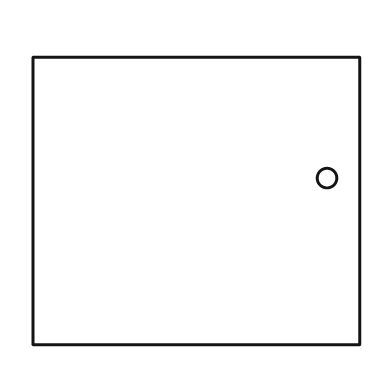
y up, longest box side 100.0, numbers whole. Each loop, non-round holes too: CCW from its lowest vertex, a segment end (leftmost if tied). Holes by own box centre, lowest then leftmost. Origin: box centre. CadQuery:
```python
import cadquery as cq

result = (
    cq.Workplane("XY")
    .moveTo(-50.0, -44.0)
    .lineTo(50.0, -44.0)
    .lineTo(50.0, 44.0)
    .lineTo(-50.0, 44.0)
    .close()
    .moveTo(40.0, 7.0)
    .circle(3.0)
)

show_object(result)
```